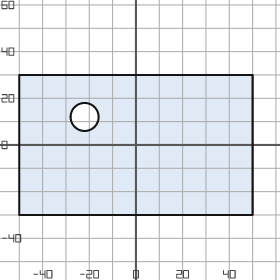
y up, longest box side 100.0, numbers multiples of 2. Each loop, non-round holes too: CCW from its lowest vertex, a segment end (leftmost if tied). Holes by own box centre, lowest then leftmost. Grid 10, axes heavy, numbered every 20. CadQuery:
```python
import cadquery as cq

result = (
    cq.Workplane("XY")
    .moveTo(-50.0, -30.0)
    .lineTo(50.0, -30.0)
    .lineTo(50.0, 30.0)
    .lineTo(-50.0, 30.0)
    .close()
    .moveTo(-22.0, 12.0)
    .circle(6.0)
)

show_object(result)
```